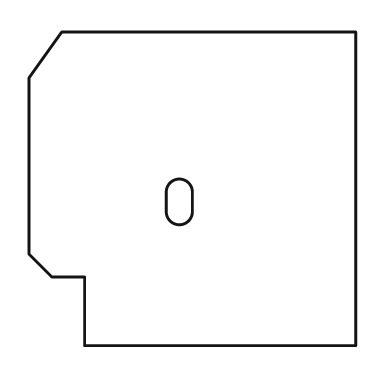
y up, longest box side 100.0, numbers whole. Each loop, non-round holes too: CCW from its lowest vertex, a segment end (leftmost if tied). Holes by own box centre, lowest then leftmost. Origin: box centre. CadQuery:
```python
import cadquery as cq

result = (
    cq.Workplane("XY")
    .moveTo(-33.0, -48.0)
    .lineTo(50.0, -48.0)
    .lineTo(50.0, 48.0)
    .lineTo(-40.0, 48.0)
    .lineTo(-50.0, 34.0)
    .lineTo(-50.0, -20.0)
    .lineTo(-43.0, -27.0)
    .lineTo(-33.0, -27.0)
    .close()
    .moveTo(-8.0, -7.0)
    .threePointArc((-4.0, -11.0), (0.0, -7.0))
    .lineTo(0.0, -1.0)
    .threePointArc((-4.0, 3.0), (-8.0, -1.0))
    .close()
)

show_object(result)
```